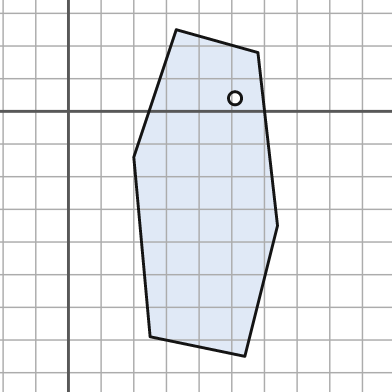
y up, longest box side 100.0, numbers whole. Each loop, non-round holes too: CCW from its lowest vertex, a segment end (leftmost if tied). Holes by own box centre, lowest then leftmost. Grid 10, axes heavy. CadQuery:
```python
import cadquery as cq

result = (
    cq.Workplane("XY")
    .moveTo(54.0, -75.0)
    .lineTo(64.0, -35.0)
    .lineTo(58.0, 18.0)
    .lineTo(33.0, 25.0)
    .lineTo(20.0, -14.0)
    .lineTo(25.0, -69.0)
    .close()
    .moveTo(51.0, 4.0)
    .circle(2.0)
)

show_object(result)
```